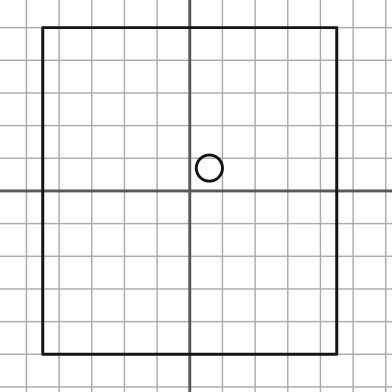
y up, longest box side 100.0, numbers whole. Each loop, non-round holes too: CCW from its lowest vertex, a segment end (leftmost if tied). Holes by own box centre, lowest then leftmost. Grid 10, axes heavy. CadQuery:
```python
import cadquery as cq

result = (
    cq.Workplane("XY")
    .moveTo(-45.0, -50.0)
    .lineTo(45.0, -50.0)
    .lineTo(45.0, 50.0)
    .lineTo(-45.0, 50.0)
    .close()
    .moveTo(6.0, 7.0)
    .circle(4.0)
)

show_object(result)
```